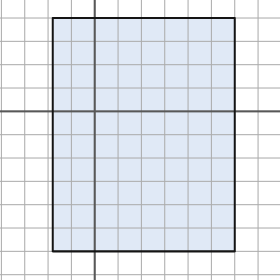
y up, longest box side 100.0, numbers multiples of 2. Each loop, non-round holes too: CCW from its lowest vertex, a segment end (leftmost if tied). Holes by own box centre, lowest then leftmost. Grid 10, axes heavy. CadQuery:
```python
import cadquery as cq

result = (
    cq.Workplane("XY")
    .moveTo(-18.0, -60.0)
    .lineTo(60.0, -60.0)
    .lineTo(60.0, 40.0)
    .lineTo(-18.0, 40.0)
    .close()
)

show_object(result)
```